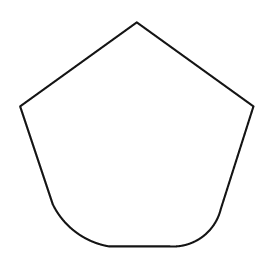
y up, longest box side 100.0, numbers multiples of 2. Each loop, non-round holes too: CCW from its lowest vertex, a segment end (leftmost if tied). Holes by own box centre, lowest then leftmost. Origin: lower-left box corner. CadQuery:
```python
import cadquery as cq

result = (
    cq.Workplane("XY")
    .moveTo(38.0, 0.0)
    .lineTo(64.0, 0.0)
    .threePointArc((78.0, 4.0), (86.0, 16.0))
    .lineTo(100.0, 60.0)
    .lineTo(50.0, 96.0)
    .lineTo(0.0, 60.0)
    .lineTo(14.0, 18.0)
    .threePointArc((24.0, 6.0), (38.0, 0.0))
    .close()
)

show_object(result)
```